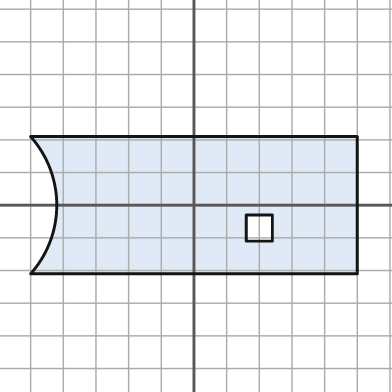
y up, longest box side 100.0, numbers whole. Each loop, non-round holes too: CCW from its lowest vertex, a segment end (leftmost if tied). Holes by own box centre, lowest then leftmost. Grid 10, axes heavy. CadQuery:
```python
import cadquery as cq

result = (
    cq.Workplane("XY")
    .moveTo(-50.0, -21.0)
    .lineTo(50.0, -21.0)
    .lineTo(50.0, 21.0)
    .lineTo(-50.0, 21.0)
    .threePointArc((-42.0, 0.0), (-50.0, -21.0))
    .close()
    .moveTo(16.0, -11.0)
    .lineTo(24.0, -11.0)
    .lineTo(24.0, -3.0)
    .lineTo(16.0, -3.0)
    .close()
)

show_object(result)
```